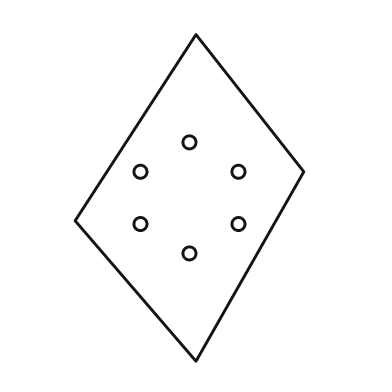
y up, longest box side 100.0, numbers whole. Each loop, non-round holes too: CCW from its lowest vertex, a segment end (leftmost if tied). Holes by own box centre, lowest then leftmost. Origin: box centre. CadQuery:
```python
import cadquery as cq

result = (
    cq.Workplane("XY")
    .moveTo(2.0, -50.0)
    .lineTo(35.0, 8.0)
    .lineTo(2.0, 50.0)
    .lineTo(-35.0, -7.0)
    .close()
    .moveTo(0.0, -17.0)
    .circle(2.0)
    .moveTo(-15.0, -8.0)
    .circle(2.0)
    .moveTo(15.0, -8.0)
    .circle(2.0)
    .moveTo(-15.0, 8.0)
    .circle(2.0)
    .moveTo(15.0, 8.0)
    .circle(2.0)
    .moveTo(0.0, 17.0)
    .circle(2.0)
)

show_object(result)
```